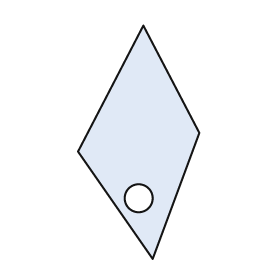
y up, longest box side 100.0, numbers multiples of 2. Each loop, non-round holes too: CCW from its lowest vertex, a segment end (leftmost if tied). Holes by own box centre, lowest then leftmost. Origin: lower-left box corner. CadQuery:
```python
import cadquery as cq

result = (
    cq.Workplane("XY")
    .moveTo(32.0, 0.0)
    .lineTo(52.0, 54.0)
    .lineTo(28.0, 100.0)
    .lineTo(0.0, 46.0)
    .close()
    .moveTo(26.0, 26.0)
    .circle(6.0)
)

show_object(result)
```